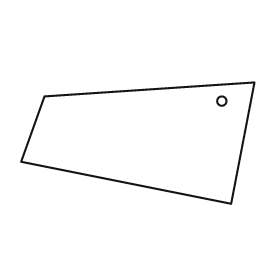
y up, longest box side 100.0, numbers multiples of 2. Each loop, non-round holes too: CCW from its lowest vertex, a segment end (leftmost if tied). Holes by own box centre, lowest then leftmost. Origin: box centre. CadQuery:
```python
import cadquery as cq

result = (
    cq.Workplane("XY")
    .moveTo(40.0, -26.0)
    .lineTo(50.0, 26.0)
    .lineTo(-40.0, 20.0)
    .lineTo(-50.0, -8.0)
    .close()
    .moveTo(36.0, 18.0)
    .circle(2.0)
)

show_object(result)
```